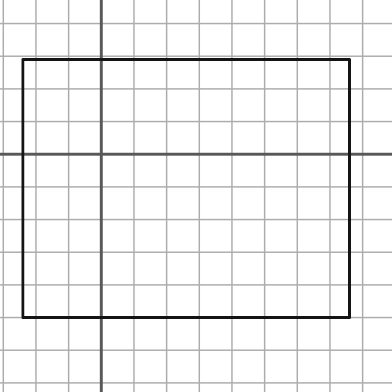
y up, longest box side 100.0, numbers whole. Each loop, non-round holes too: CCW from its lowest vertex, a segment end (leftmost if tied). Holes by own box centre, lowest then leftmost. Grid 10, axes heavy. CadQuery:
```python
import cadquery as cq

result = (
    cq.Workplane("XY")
    .moveTo(-24.0, -50.0)
    .lineTo(76.0, -50.0)
    .lineTo(76.0, 29.0)
    .lineTo(-24.0, 29.0)
    .close()
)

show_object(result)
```